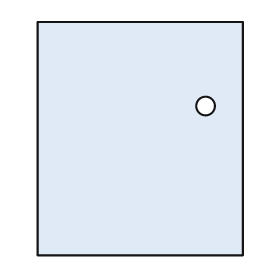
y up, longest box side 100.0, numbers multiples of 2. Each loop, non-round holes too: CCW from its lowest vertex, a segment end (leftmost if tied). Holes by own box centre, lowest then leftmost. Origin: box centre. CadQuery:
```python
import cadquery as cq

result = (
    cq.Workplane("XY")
    .moveTo(-44.0, -50.0)
    .lineTo(44.0, -50.0)
    .lineTo(44.0, 50.0)
    .lineTo(-44.0, 50.0)
    .close()
    .moveTo(28.0, 14.0)
    .circle(4.0)
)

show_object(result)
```